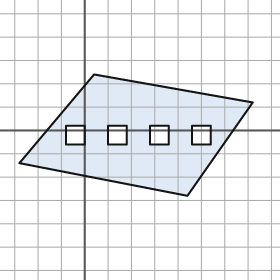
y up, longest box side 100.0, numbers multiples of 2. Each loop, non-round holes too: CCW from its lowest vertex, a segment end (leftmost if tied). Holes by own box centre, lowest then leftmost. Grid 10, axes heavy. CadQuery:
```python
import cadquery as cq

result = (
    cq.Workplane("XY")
    .moveTo(44.0, -28.0)
    .lineTo(72.0, 12.0)
    .lineTo(4.0, 24.0)
    .lineTo(-28.0, -14.0)
    .close()
    .moveTo(-8.0, -6.0)
    .lineTo(0.0, -6.0)
    .lineTo(0.0, 2.0)
    .lineTo(-8.0, 2.0)
    .close()
    .moveTo(10.0, -6.0)
    .lineTo(18.0, -6.0)
    .lineTo(18.0, 2.0)
    .lineTo(10.0, 2.0)
    .close()
    .moveTo(28.0, -6.0)
    .lineTo(36.0, -6.0)
    .lineTo(36.0, 2.0)
    .lineTo(28.0, 2.0)
    .close()
    .moveTo(46.0, -6.0)
    .lineTo(54.0, -6.0)
    .lineTo(54.0, 2.0)
    .lineTo(46.0, 2.0)
    .close()
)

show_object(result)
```